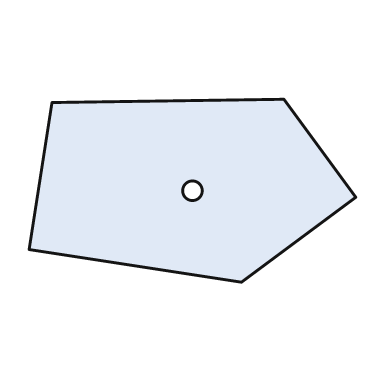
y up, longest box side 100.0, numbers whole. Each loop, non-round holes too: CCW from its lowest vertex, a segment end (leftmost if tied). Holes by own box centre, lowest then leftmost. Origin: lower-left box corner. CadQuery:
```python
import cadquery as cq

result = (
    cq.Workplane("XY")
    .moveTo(65.0, 0.0)
    .lineTo(100.0, 26.0)
    .lineTo(78.0, 56.0)
    .lineTo(7.0, 55.0)
    .lineTo(0.0, 10.0)
    .close()
    .moveTo(50.0, 28.0)
    .circle(3.0)
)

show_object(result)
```